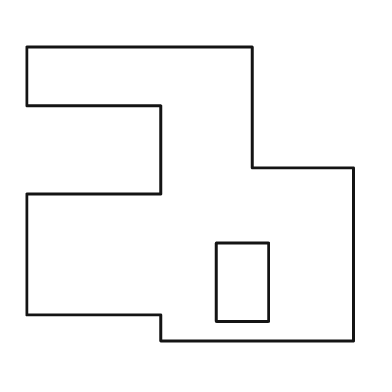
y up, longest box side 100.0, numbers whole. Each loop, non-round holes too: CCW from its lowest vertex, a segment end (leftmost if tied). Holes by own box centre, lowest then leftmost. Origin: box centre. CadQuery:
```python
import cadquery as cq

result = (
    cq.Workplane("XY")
    .moveTo(-9.0, -45.0)
    .lineTo(50.0, -45.0)
    .lineTo(50.0, 8.0)
    .lineTo(19.0, 8.0)
    .lineTo(19.0, 45.0)
    .lineTo(-50.0, 45.0)
    .lineTo(-50.0, 27.0)
    .lineTo(-9.0, 27.0)
    .lineTo(-9.0, 0.0)
    .lineTo(-50.0, 0.0)
    .lineTo(-50.0, -37.0)
    .lineTo(-9.0, -37.0)
    .close()
    .moveTo(8.0, -39.0)
    .lineTo(24.0, -39.0)
    .lineTo(24.0, -15.0)
    .lineTo(8.0, -15.0)
    .close()
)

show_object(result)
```